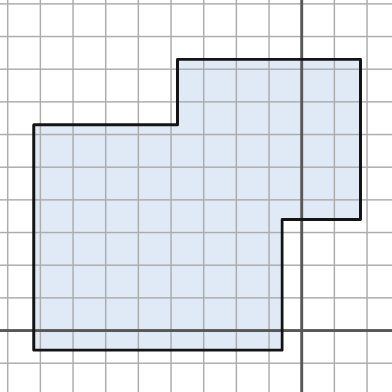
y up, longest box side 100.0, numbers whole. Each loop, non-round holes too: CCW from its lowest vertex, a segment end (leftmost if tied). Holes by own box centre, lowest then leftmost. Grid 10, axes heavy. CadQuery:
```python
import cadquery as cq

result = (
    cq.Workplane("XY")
    .moveTo(-82.0, -6.0)
    .lineTo(-6.0, -6.0)
    .lineTo(-6.0, 34.0)
    .lineTo(18.0, 34.0)
    .lineTo(18.0, 83.0)
    .lineTo(-38.0, 83.0)
    .lineTo(-38.0, 63.0)
    .lineTo(-82.0, 63.0)
    .close()
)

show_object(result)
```